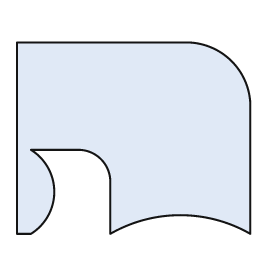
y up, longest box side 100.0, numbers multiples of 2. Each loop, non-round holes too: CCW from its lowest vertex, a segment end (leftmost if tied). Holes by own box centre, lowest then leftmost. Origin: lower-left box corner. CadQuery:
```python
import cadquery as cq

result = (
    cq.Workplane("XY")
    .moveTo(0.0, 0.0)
    .lineTo(6.0, 0.0)
    .threePointArc((16.0, 18.0), (6.0, 36.0))
    .lineTo(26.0, 36.0)
    .threePointArc((36.0, 32.0), (40.0, 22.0))
    .lineTo(40.0, 0.0)
    .threePointArc((70.0, 8.0), (100.0, 0.0))
    .lineTo(100.0, 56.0)
    .threePointArc((92.0, 74.0), (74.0, 82.0))
    .lineTo(0.0, 82.0)
    .close()
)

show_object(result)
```